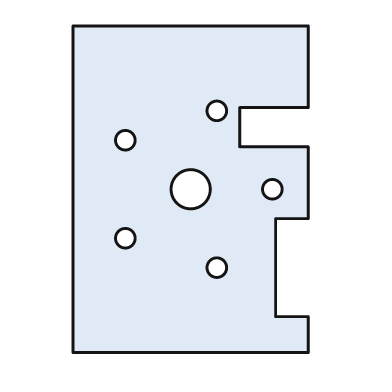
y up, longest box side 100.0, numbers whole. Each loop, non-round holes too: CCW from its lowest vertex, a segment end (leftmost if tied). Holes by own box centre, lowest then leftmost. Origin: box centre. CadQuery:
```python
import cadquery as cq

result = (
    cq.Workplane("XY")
    .moveTo(-36.0, -50.0)
    .lineTo(36.0, -50.0)
    .lineTo(36.0, -39.0)
    .lineTo(26.0, -39.0)
    .lineTo(26.0, -9.0)
    .lineTo(36.0, -9.0)
    .lineTo(36.0, 13.0)
    .lineTo(15.0, 13.0)
    .lineTo(15.0, 25.0)
    .lineTo(36.0, 25.0)
    .lineTo(36.0, 50.0)
    .lineTo(-36.0, 50.0)
    .close()
    .moveTo(8.0, -24.0)
    .circle(3.0)
    .moveTo(-20.0, -15.0)
    .circle(3.0)
    .moveTo(0.0, 0.0)
    .circle(6.0)
    .moveTo(25.0, 0.0)
    .circle(3.0)
    .moveTo(-20.0, 15.0)
    .circle(3.0)
    .moveTo(8.0, 24.0)
    .circle(3.0)
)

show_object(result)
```